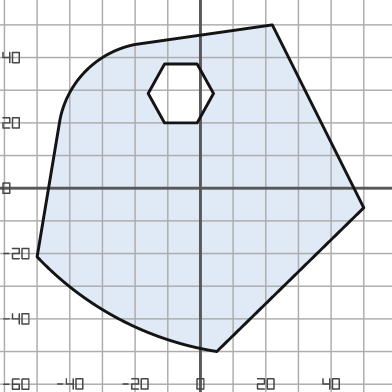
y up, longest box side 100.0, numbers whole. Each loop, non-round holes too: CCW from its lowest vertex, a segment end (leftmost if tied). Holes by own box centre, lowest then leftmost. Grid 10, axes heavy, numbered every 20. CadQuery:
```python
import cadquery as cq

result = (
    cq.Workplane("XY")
    .moveTo(5.0, -50.0)
    .lineTo(50.0, -6.0)
    .lineTo(22.0, 50.0)
    .lineTo(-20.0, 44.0)
    .threePointArc((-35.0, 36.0), (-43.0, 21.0))
    .lineTo(-50.0, -21.0)
    .threePointArc((-25.0, -40.0), (5.0, -50.0))
    .close()
    .moveTo(-11.0, 20.0)
    .lineTo(-1.0, 20.0)
    .lineTo(4.0, 29.0)
    .lineTo(-1.0, 38.0)
    .lineTo(-11.0, 38.0)
    .lineTo(-16.0, 29.0)
    .close()
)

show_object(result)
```